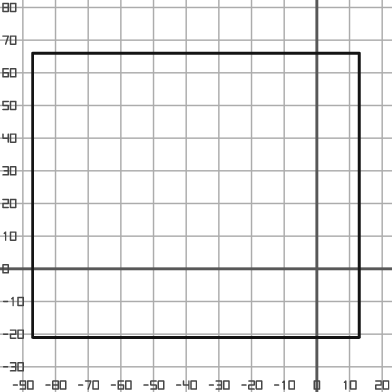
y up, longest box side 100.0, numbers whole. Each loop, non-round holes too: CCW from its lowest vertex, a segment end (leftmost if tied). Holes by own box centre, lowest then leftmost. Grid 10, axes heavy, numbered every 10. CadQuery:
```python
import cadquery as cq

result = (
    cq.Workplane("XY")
    .moveTo(-87.0, -21.0)
    .lineTo(13.0, -21.0)
    .lineTo(13.0, 66.0)
    .lineTo(-87.0, 66.0)
    .close()
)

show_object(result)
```